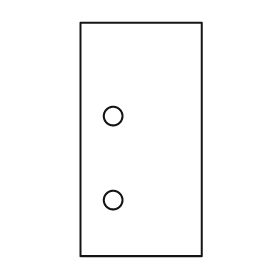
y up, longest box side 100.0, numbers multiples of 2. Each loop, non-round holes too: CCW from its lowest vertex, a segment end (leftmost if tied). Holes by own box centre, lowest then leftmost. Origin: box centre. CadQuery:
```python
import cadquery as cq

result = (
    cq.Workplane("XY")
    .moveTo(-26.0, -50.0)
    .lineTo(26.0, -50.0)
    .lineTo(26.0, 50.0)
    .lineTo(-26.0, 50.0)
    .close()
    .moveTo(-12.0, -26.0)
    .circle(4.0)
    .moveTo(-12.0, 10.0)
    .circle(4.0)
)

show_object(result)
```